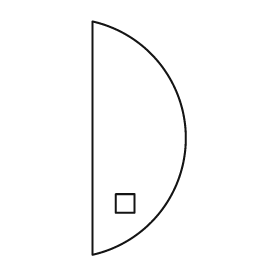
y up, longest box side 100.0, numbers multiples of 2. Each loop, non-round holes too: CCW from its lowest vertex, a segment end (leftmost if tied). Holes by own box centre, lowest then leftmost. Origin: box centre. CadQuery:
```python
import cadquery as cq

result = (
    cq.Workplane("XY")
    .moveTo(-20.0, -50.0)
    .threePointArc((20.0, 0.0), (-20.0, 50.0))
    .close()
    .moveTo(-10.0, -32.0)
    .lineTo(-2.0, -32.0)
    .lineTo(-2.0, -24.0)
    .lineTo(-10.0, -24.0)
    .close()
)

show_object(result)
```